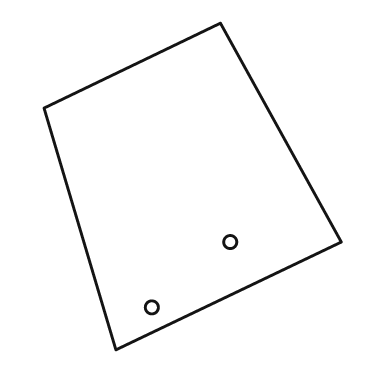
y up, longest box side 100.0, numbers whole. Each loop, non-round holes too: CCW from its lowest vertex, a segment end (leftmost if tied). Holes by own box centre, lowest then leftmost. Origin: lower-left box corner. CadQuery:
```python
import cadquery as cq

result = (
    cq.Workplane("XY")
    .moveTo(22.0, 0.0)
    .lineTo(91.0, 33.0)
    .lineTo(54.0, 100.0)
    .lineTo(0.0, 74.0)
    .close()
    .moveTo(33.0, 13.0)
    .circle(2.0)
    .moveTo(57.0, 33.0)
    .circle(2.0)
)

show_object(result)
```